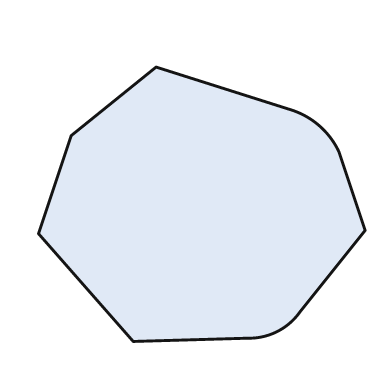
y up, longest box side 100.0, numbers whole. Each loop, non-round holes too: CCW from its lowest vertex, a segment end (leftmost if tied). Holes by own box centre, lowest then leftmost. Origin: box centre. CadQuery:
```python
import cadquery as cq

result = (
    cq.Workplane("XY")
    .moveTo(-21.0, -42.0)
    .lineTo(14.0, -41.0)
    .threePointArc((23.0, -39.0), (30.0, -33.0))
    .lineTo(50.0, -8.0)
    .lineTo(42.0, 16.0)
    .threePointArc((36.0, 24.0), (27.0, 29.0))
    .lineTo(-14.0, 42.0)
    .lineTo(-40.0, 21.0)
    .lineTo(-50.0, -9.0)
    .close()
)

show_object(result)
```